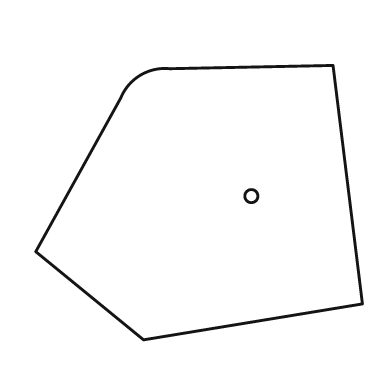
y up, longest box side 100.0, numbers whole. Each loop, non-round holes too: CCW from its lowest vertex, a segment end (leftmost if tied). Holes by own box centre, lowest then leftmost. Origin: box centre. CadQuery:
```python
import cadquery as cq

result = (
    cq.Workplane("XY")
    .moveTo(-17.0, -42.0)
    .lineTo(50.0, -31.0)
    .lineTo(41.0, 42.0)
    .lineTo(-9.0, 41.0)
    .threePointArc((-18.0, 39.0), (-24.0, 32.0))
    .lineTo(-50.0, -15.0)
    .close()
    .moveTo(16.0, 2.0)
    .circle(2.0)
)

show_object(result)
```